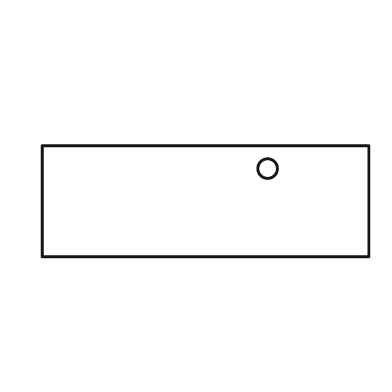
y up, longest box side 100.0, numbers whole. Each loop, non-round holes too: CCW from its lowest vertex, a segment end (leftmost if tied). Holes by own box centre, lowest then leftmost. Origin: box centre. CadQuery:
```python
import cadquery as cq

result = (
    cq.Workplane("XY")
    .moveTo(-50.0, -17.0)
    .lineTo(50.0, -17.0)
    .lineTo(50.0, 17.0)
    .lineTo(-50.0, 17.0)
    .close()
    .moveTo(19.0, 10.0)
    .circle(3.0)
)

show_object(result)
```